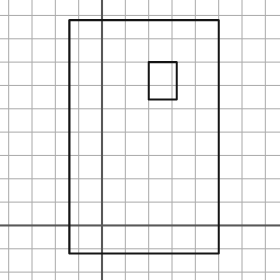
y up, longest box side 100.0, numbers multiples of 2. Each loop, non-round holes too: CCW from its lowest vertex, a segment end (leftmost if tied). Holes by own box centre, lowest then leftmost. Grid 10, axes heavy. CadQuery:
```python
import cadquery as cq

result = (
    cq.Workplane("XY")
    .moveTo(-14.0, -12.0)
    .lineTo(50.0, -12.0)
    .lineTo(50.0, 88.0)
    .lineTo(-14.0, 88.0)
    .close()
    .moveTo(20.0, 54.0)
    .lineTo(32.0, 54.0)
    .lineTo(32.0, 70.0)
    .lineTo(20.0, 70.0)
    .close()
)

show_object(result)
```